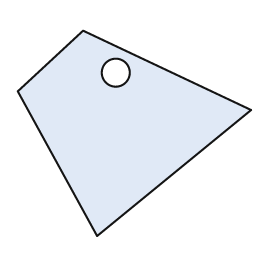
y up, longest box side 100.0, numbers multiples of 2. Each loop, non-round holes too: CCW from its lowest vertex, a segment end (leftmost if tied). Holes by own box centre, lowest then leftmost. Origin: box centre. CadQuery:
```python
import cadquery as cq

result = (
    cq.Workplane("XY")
    .moveTo(-16.0, -44.0)
    .lineTo(50.0, 10.0)
    .lineTo(-22.0, 44.0)
    .lineTo(-50.0, 18.0)
    .close()
    .moveTo(-8.0, 26.0)
    .circle(6.0)
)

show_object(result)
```